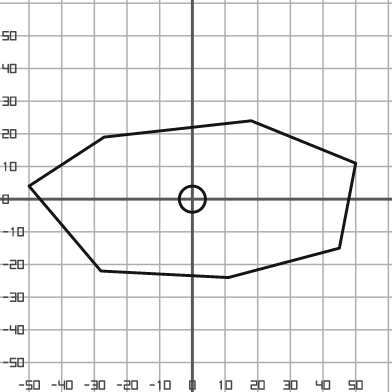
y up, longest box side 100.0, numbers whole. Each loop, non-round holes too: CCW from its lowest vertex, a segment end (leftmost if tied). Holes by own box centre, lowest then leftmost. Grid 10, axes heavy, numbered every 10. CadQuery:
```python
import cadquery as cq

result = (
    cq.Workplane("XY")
    .moveTo(11.0, -24.0)
    .lineTo(45.0, -15.0)
    .lineTo(50.0, 11.0)
    .lineTo(18.0, 24.0)
    .lineTo(-27.0, 19.0)
    .lineTo(-50.0, 4.0)
    .lineTo(-28.0, -22.0)
    .close()
    .moveTo(0.0, 0.0)
    .circle(4.0)
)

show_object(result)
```